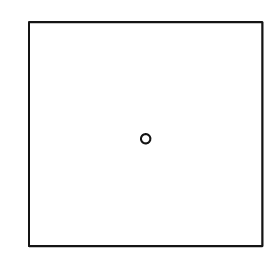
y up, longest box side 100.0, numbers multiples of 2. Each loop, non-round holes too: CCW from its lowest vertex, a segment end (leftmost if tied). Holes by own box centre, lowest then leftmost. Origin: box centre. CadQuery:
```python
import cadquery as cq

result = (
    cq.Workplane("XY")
    .moveTo(-50.0, -48.0)
    .lineTo(50.0, -48.0)
    .lineTo(50.0, 48.0)
    .lineTo(-50.0, 48.0)
    .close()
    .moveTo(0.0, -2.0)
    .circle(2.0)
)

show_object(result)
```